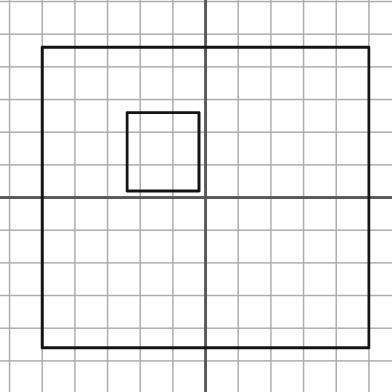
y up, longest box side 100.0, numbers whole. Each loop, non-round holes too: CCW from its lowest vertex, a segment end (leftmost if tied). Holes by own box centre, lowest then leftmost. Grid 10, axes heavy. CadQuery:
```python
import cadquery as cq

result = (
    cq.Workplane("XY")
    .moveTo(-50.0, -46.0)
    .lineTo(50.0, -46.0)
    .lineTo(50.0, 46.0)
    .lineTo(-50.0, 46.0)
    .close()
    .moveTo(-24.0, 2.0)
    .lineTo(-2.0, 2.0)
    .lineTo(-2.0, 26.0)
    .lineTo(-24.0, 26.0)
    .close()
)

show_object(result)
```